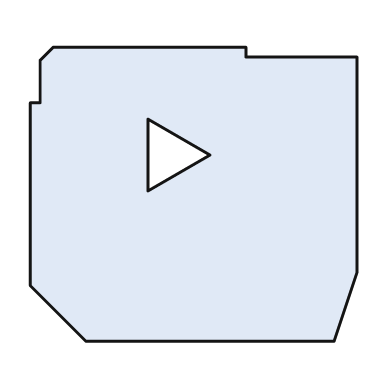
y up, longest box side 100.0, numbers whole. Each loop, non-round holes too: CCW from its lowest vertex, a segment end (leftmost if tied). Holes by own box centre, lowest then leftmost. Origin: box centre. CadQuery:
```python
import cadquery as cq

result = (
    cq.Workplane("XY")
    .moveTo(-33.0, -45.0)
    .lineTo(43.0, -45.0)
    .lineTo(50.0, -24.0)
    .lineTo(50.0, 42.0)
    .lineTo(16.0, 42.0)
    .lineTo(16.0, 45.0)
    .lineTo(-43.0, 45.0)
    .lineTo(-47.0, 41.0)
    .lineTo(-47.0, 28.0)
    .lineTo(-50.0, 28.0)
    .lineTo(-50.0, -28.0)
    .close()
    .moveTo(-14.0, 1.0)
    .lineTo(5.0, 12.0)
    .lineTo(-14.0, 23.0)
    .close()
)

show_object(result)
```